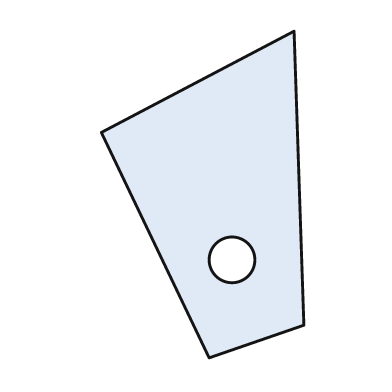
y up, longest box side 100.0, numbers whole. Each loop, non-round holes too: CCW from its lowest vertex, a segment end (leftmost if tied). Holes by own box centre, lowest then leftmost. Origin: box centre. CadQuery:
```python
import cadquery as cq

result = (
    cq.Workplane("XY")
    .moveTo(2.0, -50.0)
    .lineTo(31.0, -40.0)
    .lineTo(28.0, 50.0)
    .lineTo(-31.0, 19.0)
    .close()
    .moveTo(9.0, -20.0)
    .circle(7.0)
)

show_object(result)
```